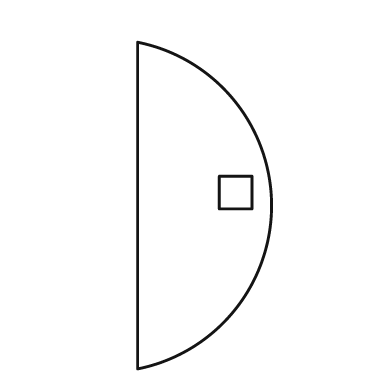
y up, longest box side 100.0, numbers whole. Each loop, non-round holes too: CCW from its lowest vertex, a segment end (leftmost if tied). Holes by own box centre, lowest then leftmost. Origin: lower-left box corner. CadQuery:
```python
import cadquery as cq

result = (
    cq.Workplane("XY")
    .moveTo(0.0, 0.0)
    .threePointArc((41.0, 50.0), (0.0, 100.0))
    .close()
    .moveTo(25.0, 49.0)
    .lineTo(35.0, 49.0)
    .lineTo(35.0, 59.0)
    .lineTo(25.0, 59.0)
    .close()
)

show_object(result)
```